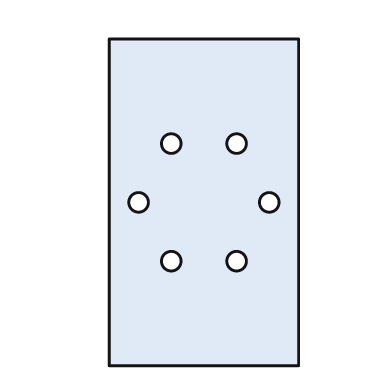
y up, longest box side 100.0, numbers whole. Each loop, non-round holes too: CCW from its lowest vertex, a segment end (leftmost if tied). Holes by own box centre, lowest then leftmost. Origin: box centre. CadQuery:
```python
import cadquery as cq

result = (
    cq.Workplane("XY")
    .moveTo(-29.0, -50.0)
    .lineTo(29.0, -50.0)
    .lineTo(29.0, 50.0)
    .lineTo(-29.0, 50.0)
    .close()
    .moveTo(-10.0, -18.0)
    .circle(3.0)
    .moveTo(10.0, -18.0)
    .circle(3.0)
    .moveTo(-20.0, 0.0)
    .circle(3.0)
    .moveTo(20.0, 0.0)
    .circle(3.0)
    .moveTo(-10.0, 18.0)
    .circle(3.0)
    .moveTo(10.0, 18.0)
    .circle(3.0)
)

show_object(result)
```